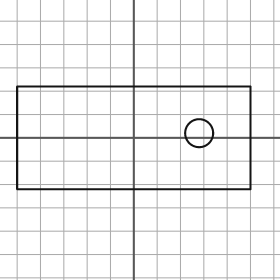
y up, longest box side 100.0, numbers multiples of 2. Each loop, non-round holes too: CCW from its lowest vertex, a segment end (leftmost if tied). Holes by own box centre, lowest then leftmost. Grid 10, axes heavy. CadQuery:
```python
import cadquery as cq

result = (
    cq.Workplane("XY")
    .moveTo(-50.0, -22.0)
    .lineTo(50.0, -22.0)
    .lineTo(50.0, 22.0)
    .lineTo(-50.0, 22.0)
    .close()
    .moveTo(28.0, 2.0)
    .circle(6.0)
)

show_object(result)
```